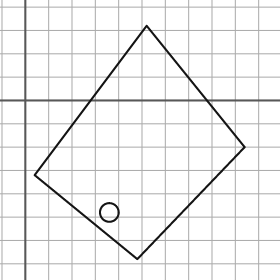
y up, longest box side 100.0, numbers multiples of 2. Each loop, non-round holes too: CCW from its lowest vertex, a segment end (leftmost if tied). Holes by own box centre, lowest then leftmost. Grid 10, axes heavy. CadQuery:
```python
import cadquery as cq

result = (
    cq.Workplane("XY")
    .moveTo(48.0, -68.0)
    .lineTo(94.0, -20.0)
    .lineTo(52.0, 32.0)
    .lineTo(4.0, -32.0)
    .close()
    .moveTo(36.0, -48.0)
    .circle(4.0)
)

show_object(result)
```